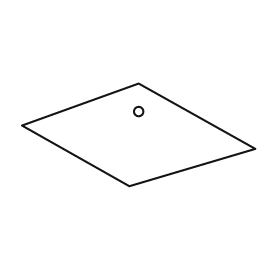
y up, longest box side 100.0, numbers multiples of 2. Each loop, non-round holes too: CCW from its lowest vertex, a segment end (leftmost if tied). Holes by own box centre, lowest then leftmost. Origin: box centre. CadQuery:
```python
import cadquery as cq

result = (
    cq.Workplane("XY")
    .moveTo(-4.0, -22.0)
    .lineTo(50.0, -6.0)
    .lineTo(0.0, 22.0)
    .lineTo(-50.0, 4.0)
    .close()
    .moveTo(0.0, 10.0)
    .circle(2.0)
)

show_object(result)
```